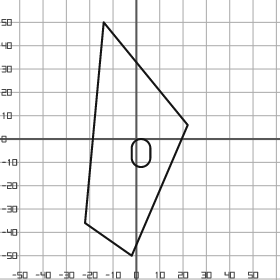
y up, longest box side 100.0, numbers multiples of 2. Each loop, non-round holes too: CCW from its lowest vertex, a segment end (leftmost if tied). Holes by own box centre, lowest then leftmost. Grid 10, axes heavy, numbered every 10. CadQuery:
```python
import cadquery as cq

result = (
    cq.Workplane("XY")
    .moveTo(-2.0, -50.0)
    .lineTo(22.0, 6.0)
    .lineTo(-14.0, 50.0)
    .lineTo(-22.0, -36.0)
    .close()
    .moveTo(-2.0, -8.0)
    .threePointArc((2.0, -12.0), (6.0, -8.0))
    .lineTo(6.0, -4.0)
    .threePointArc((2.0, 0.0), (-2.0, -4.0))
    .close()
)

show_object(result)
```